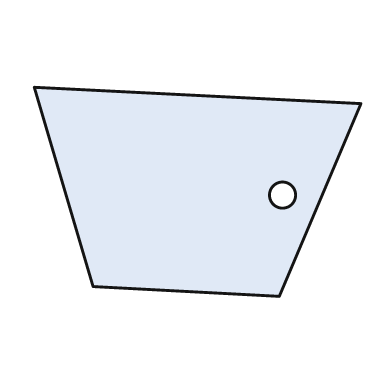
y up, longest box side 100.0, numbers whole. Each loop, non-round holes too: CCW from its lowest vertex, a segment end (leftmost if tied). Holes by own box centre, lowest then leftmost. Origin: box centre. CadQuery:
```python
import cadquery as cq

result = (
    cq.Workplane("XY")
    .moveTo(25.0, -32.0)
    .lineTo(50.0, 27.0)
    .lineTo(-50.0, 32.0)
    .lineTo(-32.0, -29.0)
    .close()
    .moveTo(26.0, -1.0)
    .circle(4.0)
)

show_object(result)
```